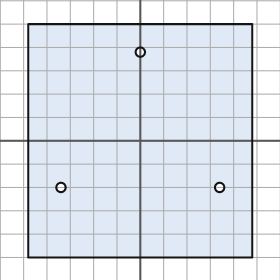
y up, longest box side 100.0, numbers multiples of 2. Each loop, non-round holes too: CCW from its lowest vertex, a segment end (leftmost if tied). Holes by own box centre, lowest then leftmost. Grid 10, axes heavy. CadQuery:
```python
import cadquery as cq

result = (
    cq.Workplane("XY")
    .moveTo(-48.0, -50.0)
    .lineTo(48.0, -50.0)
    .lineTo(48.0, 50.0)
    .lineTo(-48.0, 50.0)
    .close()
    .moveTo(-34.0, -20.0)
    .circle(2.0)
    .moveTo(34.0, -20.0)
    .circle(2.0)
    .moveTo(0.0, 38.0)
    .circle(2.0)
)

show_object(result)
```